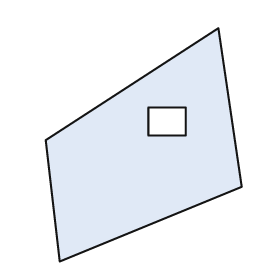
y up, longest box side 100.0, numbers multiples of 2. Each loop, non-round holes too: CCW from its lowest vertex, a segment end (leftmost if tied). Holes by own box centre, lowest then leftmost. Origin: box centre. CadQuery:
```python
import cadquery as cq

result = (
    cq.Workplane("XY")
    .moveTo(-36.0, -50.0)
    .lineTo(42.0, -18.0)
    .lineTo(32.0, 50.0)
    .lineTo(-42.0, 2.0)
    .close()
    .moveTo(2.0, 4.0)
    .lineTo(18.0, 4.0)
    .lineTo(18.0, 16.0)
    .lineTo(2.0, 16.0)
    .close()
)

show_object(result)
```